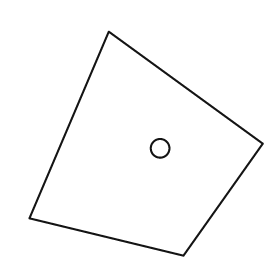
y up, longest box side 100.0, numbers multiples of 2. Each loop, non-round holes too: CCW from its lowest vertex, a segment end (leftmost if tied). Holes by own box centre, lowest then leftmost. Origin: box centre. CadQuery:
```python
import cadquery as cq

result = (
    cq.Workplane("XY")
    .moveTo(16.0, -48.0)
    .lineTo(50.0, 0.0)
    .lineTo(-16.0, 48.0)
    .lineTo(-50.0, -32.0)
    .close()
    .moveTo(6.0, -2.0)
    .circle(4.0)
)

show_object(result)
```